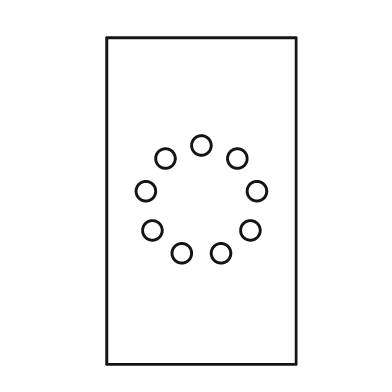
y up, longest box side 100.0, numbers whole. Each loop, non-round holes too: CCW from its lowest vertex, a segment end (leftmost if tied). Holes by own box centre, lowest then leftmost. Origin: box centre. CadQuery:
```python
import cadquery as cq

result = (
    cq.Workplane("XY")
    .moveTo(-29.0, -50.0)
    .lineTo(29.0, -50.0)
    .lineTo(29.0, 50.0)
    .lineTo(-29.0, 50.0)
    .close()
    .moveTo(-6.0, -16.0)
    .circle(3.0)
    .moveTo(6.0, -16.0)
    .circle(3.0)
    .moveTo(-15.0, -9.0)
    .circle(3.0)
    .moveTo(15.0, -9.0)
    .circle(3.0)
    .moveTo(-17.0, 3.0)
    .circle(3.0)
    .moveTo(17.0, 3.0)
    .circle(3.0)
    .moveTo(-11.0, 13.0)
    .circle(3.0)
    .moveTo(11.0, 13.0)
    .circle(3.0)
    .moveTo(0.0, 17.0)
    .circle(3.0)
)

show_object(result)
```